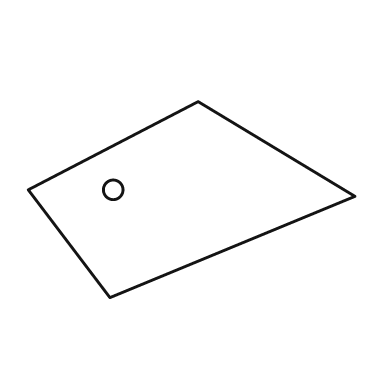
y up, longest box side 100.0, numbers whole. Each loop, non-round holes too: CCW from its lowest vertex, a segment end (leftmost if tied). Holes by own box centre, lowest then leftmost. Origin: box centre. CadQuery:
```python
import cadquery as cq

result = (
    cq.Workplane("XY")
    .moveTo(-25.0, -30.0)
    .lineTo(50.0, 1.0)
    .lineTo(2.0, 30.0)
    .lineTo(-50.0, 3.0)
    .close()
    .moveTo(-24.0, 3.0)
    .circle(3.0)
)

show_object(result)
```